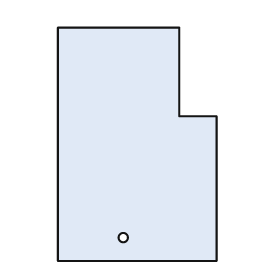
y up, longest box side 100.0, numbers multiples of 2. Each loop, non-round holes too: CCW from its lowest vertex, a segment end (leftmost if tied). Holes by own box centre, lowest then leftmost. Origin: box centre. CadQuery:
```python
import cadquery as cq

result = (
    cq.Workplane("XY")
    .moveTo(-34.0, -50.0)
    .lineTo(34.0, -50.0)
    .lineTo(34.0, 12.0)
    .lineTo(18.0, 12.0)
    .lineTo(18.0, 50.0)
    .lineTo(-34.0, 50.0)
    .close()
    .moveTo(-6.0, -40.0)
    .circle(2.0)
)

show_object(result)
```